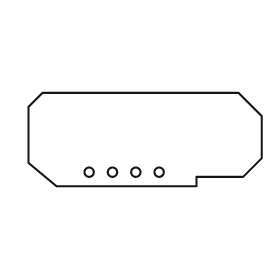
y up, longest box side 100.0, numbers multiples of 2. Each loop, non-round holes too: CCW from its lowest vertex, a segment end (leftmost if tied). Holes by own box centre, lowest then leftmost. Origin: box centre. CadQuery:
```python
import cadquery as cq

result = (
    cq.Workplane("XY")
    .moveTo(-38.0, -20.0)
    .lineTo(22.0, -20.0)
    .lineTo(22.0, -16.0)
    .lineTo(42.0, -16.0)
    .lineTo(50.0, -8.0)
    .lineTo(50.0, 10.0)
    .lineTo(40.0, 20.0)
    .lineTo(-44.0, 20.0)
    .lineTo(-50.0, 14.0)
    .lineTo(-50.0, -10.0)
    .close()
    .moveTo(-24.0, -14.0)
    .circle(2.0)
    .moveTo(-14.0, -14.0)
    .circle(2.0)
    .moveTo(-4.0, -14.0)
    .circle(2.0)
    .moveTo(6.0, -14.0)
    .circle(2.0)
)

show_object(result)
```